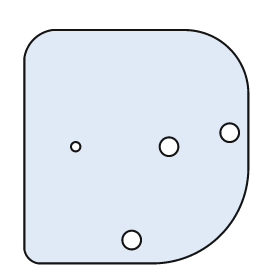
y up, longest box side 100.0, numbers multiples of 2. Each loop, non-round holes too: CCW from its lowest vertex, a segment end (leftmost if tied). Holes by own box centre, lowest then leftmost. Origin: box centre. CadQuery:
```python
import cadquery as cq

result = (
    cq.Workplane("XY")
    .moveTo(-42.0, -50.0)
    .lineTo(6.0, -50.0)
    .threePointArc((36.0, -38.0), (48.0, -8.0))
    .lineTo(48.0, 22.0)
    .threePointArc((40.0, 42.0), (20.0, 50.0))
    .lineTo(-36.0, 50.0)
    .threePointArc((-44.0, 46.0), (-48.0, 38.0))
    .lineTo(-48.0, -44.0)
    .threePointArc((-46.0, -48.0), (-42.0, -50.0))
    .close()
    .moveTo(-2.0, -40.0)
    .circle(4.0)
    .moveTo(-26.0, 0.0)
    .circle(2.0)
    .moveTo(14.0, 0.0)
    .circle(4.0)
    .moveTo(40.0, 6.0)
    .circle(4.0)
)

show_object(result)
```